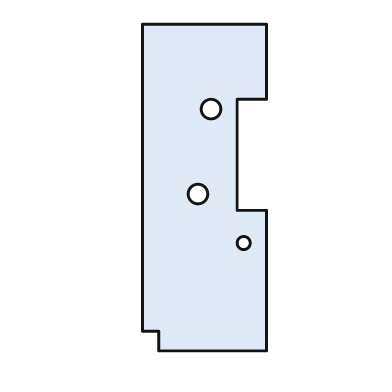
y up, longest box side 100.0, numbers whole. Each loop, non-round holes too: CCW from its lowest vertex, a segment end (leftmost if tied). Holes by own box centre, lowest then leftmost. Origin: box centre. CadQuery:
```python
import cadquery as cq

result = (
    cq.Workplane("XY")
    .moveTo(-14.0, -50.0)
    .lineTo(19.0, -50.0)
    .lineTo(19.0, -7.0)
    .lineTo(10.0, -7.0)
    .lineTo(10.0, 27.0)
    .lineTo(19.0, 27.0)
    .lineTo(19.0, 50.0)
    .lineTo(-19.0, 50.0)
    .lineTo(-19.0, -44.0)
    .lineTo(-14.0, -44.0)
    .close()
    .moveTo(12.0, -17.0)
    .circle(2.0)
    .moveTo(-2.0, -2.0)
    .circle(3.0)
    .moveTo(2.0, 24.0)
    .circle(3.0)
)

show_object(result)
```